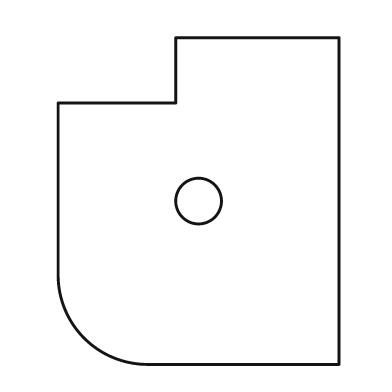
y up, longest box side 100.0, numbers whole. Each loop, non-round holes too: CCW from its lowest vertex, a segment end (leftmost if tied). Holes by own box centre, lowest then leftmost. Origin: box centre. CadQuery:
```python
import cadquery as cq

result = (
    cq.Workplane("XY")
    .moveTo(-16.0, -50.0)
    .lineTo(43.0, -50.0)
    .lineTo(43.0, 50.0)
    .lineTo(-7.0, 50.0)
    .lineTo(-7.0, 30.0)
    .lineTo(-43.0, 30.0)
    .lineTo(-43.0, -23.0)
    .threePointArc((-35.0, -42.0), (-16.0, -50.0))
    .close()
    .moveTo(0.0, 0.0)
    .circle(7.0)
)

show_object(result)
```